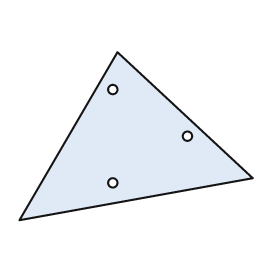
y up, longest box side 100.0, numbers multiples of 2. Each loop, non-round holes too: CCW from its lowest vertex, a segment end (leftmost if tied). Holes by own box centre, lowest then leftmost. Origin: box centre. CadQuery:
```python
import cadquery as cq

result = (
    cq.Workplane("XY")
    .moveTo(-50.0, -36.0)
    .lineTo(50.0, -18.0)
    .lineTo(-8.0, 36.0)
    .close()
    .moveTo(-10.0, -20.0)
    .circle(2.0)
    .moveTo(22.0, 0.0)
    .circle(2.0)
    .moveTo(-10.0, 20.0)
    .circle(2.0)
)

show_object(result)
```